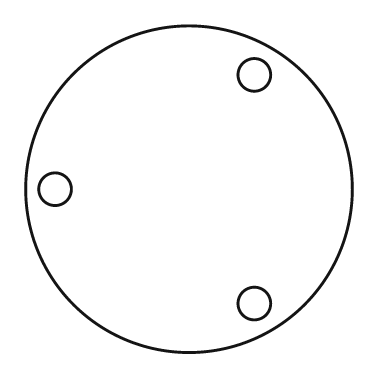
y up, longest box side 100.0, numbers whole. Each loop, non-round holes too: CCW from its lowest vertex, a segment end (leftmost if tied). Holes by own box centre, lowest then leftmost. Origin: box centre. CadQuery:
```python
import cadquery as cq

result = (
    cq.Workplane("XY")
    .moveTo(0.0, 0.0)
    .circle(50.0)
    .moveTo(20.0, -35.0)
    .circle(5.0)
    .moveTo(-41.0, 0.0)
    .circle(5.0)
    .moveTo(20.0, 35.0)
    .circle(5.0)
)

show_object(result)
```